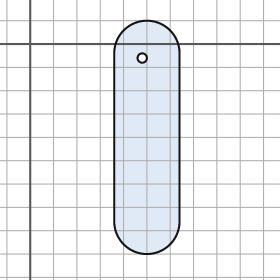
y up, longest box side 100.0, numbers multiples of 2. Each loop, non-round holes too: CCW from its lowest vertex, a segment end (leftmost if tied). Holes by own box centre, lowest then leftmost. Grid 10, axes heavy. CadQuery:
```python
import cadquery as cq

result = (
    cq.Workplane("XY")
    .moveTo(36.0, -76.0)
    .threePointArc((50.0, -90.0), (64.0, -76.0))
    .lineTo(64.0, -4.0)
    .threePointArc((50.0, 10.0), (36.0, -4.0))
    .close()
    .moveTo(48.0, -6.0)
    .circle(2.0)
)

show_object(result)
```